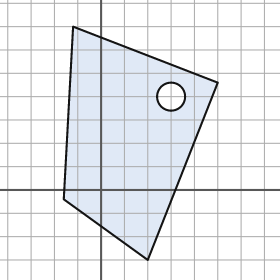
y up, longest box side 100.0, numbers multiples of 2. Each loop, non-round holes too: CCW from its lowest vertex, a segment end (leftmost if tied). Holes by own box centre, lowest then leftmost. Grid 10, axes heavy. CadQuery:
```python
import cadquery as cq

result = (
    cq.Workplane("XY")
    .moveTo(20.0, -30.0)
    .lineTo(50.0, 46.0)
    .lineTo(-12.0, 70.0)
    .lineTo(-16.0, -4.0)
    .close()
    .moveTo(30.0, 40.0)
    .circle(6.0)
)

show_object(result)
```